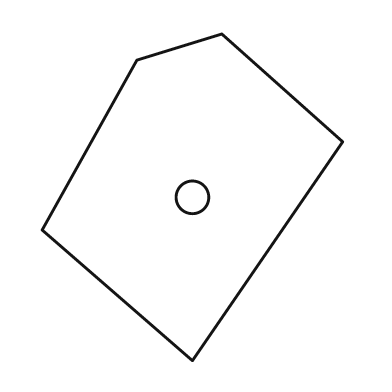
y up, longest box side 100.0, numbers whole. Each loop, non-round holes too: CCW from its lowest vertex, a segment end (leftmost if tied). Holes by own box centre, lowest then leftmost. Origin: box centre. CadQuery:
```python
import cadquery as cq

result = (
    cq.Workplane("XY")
    .moveTo(0.0, -50.0)
    .lineTo(46.0, 17.0)
    .lineTo(9.0, 50.0)
    .lineTo(-17.0, 42.0)
    .lineTo(-46.0, -10.0)
    .close()
    .moveTo(0.0, 0.0)
    .circle(5.0)
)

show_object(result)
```